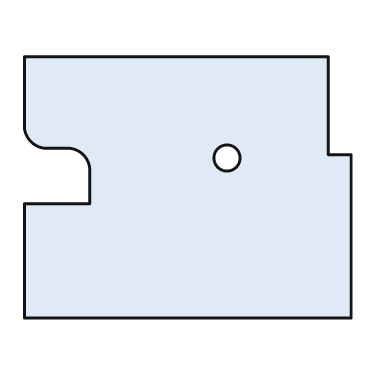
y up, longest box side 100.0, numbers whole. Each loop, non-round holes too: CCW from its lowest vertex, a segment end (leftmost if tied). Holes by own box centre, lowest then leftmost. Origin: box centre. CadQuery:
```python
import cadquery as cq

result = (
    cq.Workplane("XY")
    .moveTo(-50.0, -40.0)
    .lineTo(50.0, -40.0)
    .lineTo(50.0, 10.0)
    .lineTo(43.0, 10.0)
    .lineTo(43.0, 40.0)
    .lineTo(-50.0, 40.0)
    .lineTo(-50.0, 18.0)
    .threePointArc((-48.0, 14.0), (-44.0, 12.0))
    .lineTo(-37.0, 12.0)
    .threePointArc((-32.0, 10.0), (-30.0, 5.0))
    .lineTo(-30.0, -5.0)
    .lineTo(-50.0, -5.0)
    .close()
    .moveTo(12.0, 9.0)
    .circle(4.0)
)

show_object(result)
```